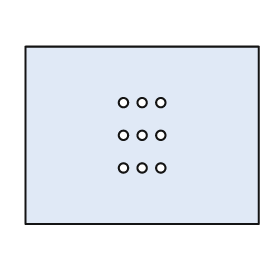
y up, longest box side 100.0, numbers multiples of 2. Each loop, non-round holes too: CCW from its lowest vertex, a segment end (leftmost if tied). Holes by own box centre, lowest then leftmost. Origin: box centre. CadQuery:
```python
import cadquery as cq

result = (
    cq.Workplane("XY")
    .moveTo(-50.0, -38.0)
    .lineTo(50.0, -38.0)
    .lineTo(50.0, 38.0)
    .lineTo(-50.0, 38.0)
    .close()
    .moveTo(-8.0, -14.0)
    .circle(2.0)
    .moveTo(0.0, -14.0)
    .circle(2.0)
    .moveTo(8.0, -14.0)
    .circle(2.0)
    .moveTo(-8.0, 0.0)
    .circle(2.0)
    .moveTo(0.0, 0.0)
    .circle(2.0)
    .moveTo(8.0, 0.0)
    .circle(2.0)
    .moveTo(-8.0, 14.0)
    .circle(2.0)
    .moveTo(0.0, 14.0)
    .circle(2.0)
    .moveTo(8.0, 14.0)
    .circle(2.0)
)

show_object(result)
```